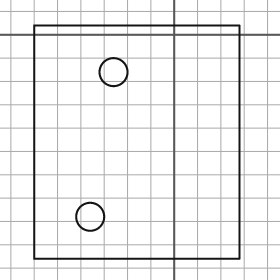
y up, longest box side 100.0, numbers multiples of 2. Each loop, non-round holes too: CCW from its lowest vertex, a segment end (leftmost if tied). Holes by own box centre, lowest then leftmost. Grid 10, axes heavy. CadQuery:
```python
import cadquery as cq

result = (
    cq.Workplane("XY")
    .moveTo(-60.0, -96.0)
    .lineTo(28.0, -96.0)
    .lineTo(28.0, 4.0)
    .lineTo(-60.0, 4.0)
    .close()
    .moveTo(-36.0, -78.0)
    .circle(6.0)
    .moveTo(-26.0, -16.0)
    .circle(6.0)
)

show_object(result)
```